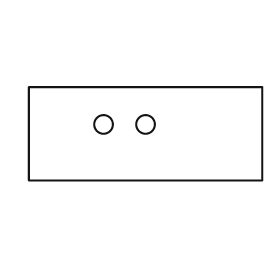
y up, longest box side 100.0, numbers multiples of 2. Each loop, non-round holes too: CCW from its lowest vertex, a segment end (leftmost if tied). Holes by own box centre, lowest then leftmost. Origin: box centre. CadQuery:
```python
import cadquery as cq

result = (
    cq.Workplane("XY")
    .moveTo(-50.0, -20.0)
    .lineTo(50.0, -20.0)
    .lineTo(50.0, 20.0)
    .lineTo(-50.0, 20.0)
    .close()
    .moveTo(-18.0, 4.0)
    .circle(4.0)
    .moveTo(0.0, 4.0)
    .circle(4.0)
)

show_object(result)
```